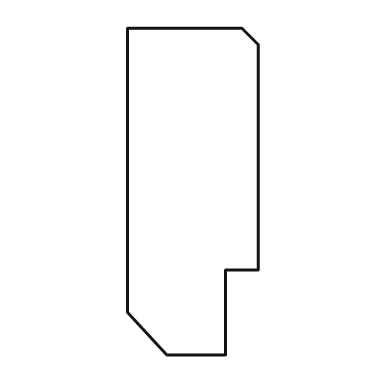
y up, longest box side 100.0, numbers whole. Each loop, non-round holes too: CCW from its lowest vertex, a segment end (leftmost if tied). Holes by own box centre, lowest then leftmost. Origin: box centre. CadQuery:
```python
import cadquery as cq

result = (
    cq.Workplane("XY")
    .moveTo(-8.0, -50.0)
    .lineTo(10.0, -50.0)
    .lineTo(10.0, -24.0)
    .lineTo(20.0, -24.0)
    .lineTo(20.0, 45.0)
    .lineTo(15.0, 50.0)
    .lineTo(-20.0, 50.0)
    .lineTo(-20.0, -37.0)
    .close()
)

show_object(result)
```